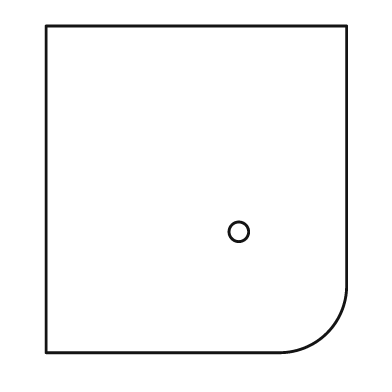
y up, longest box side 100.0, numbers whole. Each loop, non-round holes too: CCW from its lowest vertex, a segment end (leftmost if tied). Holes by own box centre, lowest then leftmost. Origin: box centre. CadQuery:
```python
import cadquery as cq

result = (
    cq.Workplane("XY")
    .moveTo(-46.0, -50.0)
    .lineTo(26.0, -50.0)
    .threePointArc((40.0, -44.0), (46.0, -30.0))
    .lineTo(46.0, 50.0)
    .lineTo(-46.0, 50.0)
    .close()
    .moveTo(13.0, -13.0)
    .circle(3.0)
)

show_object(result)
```